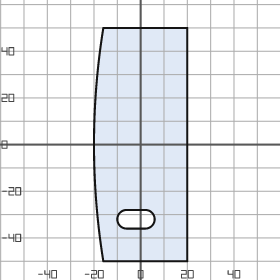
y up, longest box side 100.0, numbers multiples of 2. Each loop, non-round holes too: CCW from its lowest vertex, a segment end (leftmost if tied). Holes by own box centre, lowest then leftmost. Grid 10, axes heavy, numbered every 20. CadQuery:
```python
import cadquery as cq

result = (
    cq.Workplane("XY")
    .moveTo(-16.0, -50.0)
    .lineTo(20.0, -50.0)
    .lineTo(20.0, 50.0)
    .lineTo(-16.0, 50.0)
    .threePointArc((-20.0, 0.0), (-16.0, -50.0))
    .close()
    .moveTo(-6.0, -36.0)
    .lineTo(2.0, -36.0)
    .threePointArc((6.0, -32.0), (2.0, -28.0))
    .lineTo(-6.0, -28.0)
    .threePointArc((-10.0, -32.0), (-6.0, -36.0))
    .close()
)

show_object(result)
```